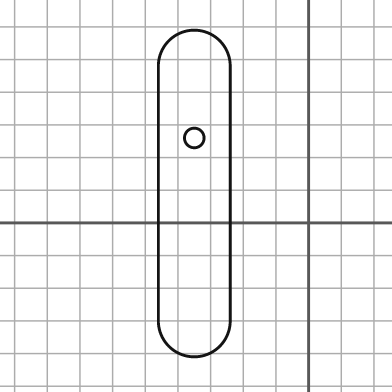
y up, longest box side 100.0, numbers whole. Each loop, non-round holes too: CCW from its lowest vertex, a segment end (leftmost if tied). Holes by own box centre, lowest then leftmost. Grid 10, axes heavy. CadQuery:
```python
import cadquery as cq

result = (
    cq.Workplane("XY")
    .moveTo(-46.0, -30.0)
    .threePointArc((-35.0, -41.0), (-24.0, -30.0))
    .lineTo(-24.0, 48.0)
    .threePointArc((-35.0, 59.0), (-46.0, 48.0))
    .close()
    .moveTo(-35.0, 26.0)
    .circle(3.0)
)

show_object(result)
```